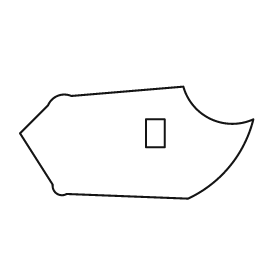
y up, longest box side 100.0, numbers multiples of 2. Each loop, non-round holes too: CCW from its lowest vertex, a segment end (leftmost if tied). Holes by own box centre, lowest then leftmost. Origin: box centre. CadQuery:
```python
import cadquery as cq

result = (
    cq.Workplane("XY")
    .moveTo(22.0, -24.0)
    .threePointArc((40.0, -10.0), (50.0, 10.0))
    .threePointArc((32.0, 10.0), (20.0, 24.0))
    .lineTo(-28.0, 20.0)
    .threePointArc((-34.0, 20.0), (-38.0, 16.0))
    .lineTo(-50.0, 4.0)
    .lineTo(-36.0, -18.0)
    .threePointArc((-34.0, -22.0), (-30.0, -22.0))
    .close()
    .moveTo(4.0, -2.0)
    .lineTo(12.0, -2.0)
    .lineTo(12.0, 10.0)
    .lineTo(4.0, 10.0)
    .close()
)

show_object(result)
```